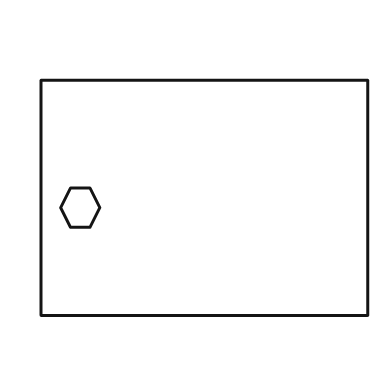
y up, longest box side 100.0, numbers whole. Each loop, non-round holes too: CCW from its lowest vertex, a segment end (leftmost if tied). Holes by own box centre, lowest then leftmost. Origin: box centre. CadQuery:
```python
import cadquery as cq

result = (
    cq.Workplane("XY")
    .moveTo(-50.0, -36.0)
    .lineTo(50.0, -36.0)
    .lineTo(50.0, 36.0)
    .lineTo(-50.0, 36.0)
    .close()
    .moveTo(-41.0, -9.0)
    .lineTo(-35.0, -9.0)
    .lineTo(-32.0, -3.0)
    .lineTo(-35.0, 3.0)
    .lineTo(-41.0, 3.0)
    .lineTo(-44.0, -3.0)
    .close()
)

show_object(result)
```